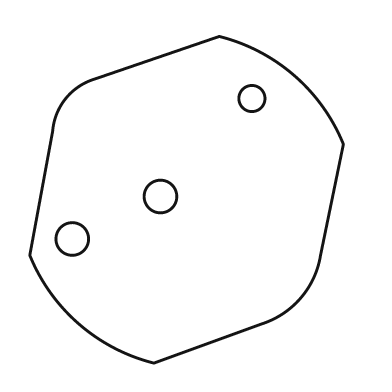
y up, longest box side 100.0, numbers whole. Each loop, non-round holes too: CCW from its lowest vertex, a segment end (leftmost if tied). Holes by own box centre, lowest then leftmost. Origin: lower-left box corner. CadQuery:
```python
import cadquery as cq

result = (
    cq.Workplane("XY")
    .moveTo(38.0, 0.0)
    .lineTo(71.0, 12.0)
    .threePointArc((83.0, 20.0), (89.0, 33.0))
    .lineTo(96.0, 67.0)
    .threePointArc((81.0, 88.0), (58.0, 100.0))
    .lineTo(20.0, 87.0)
    .threePointArc((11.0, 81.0), (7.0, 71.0))
    .lineTo(0.0, 33.0)
    .threePointArc((15.0, 12.0), (38.0, 0.0))
    .close()
    .moveTo(13.0, 38.0)
    .circle(5.0)
    .moveTo(40.0, 51.0)
    .circle(5.0)
    .moveTo(68.0, 81.0)
    .circle(4.0)
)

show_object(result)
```